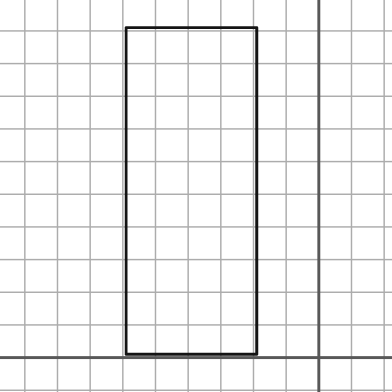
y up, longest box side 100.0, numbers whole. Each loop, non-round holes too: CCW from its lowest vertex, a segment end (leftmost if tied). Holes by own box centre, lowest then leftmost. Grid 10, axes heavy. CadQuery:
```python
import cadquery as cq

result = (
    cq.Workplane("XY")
    .moveTo(-59.0, 1.0)
    .lineTo(-19.0, 1.0)
    .lineTo(-19.0, 101.0)
    .lineTo(-59.0, 101.0)
    .close()
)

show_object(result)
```